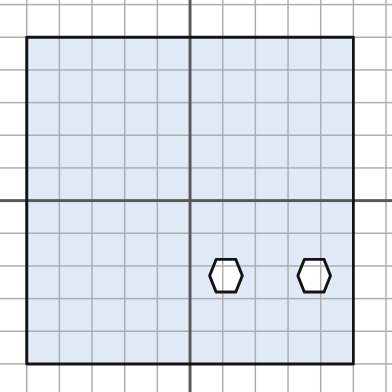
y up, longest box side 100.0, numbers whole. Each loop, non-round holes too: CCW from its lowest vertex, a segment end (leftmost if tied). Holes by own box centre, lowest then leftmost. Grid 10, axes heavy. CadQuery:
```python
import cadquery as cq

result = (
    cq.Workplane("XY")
    .moveTo(-50.0, -50.0)
    .lineTo(50.0, -50.0)
    .lineTo(50.0, 50.0)
    .lineTo(-50.0, 50.0)
    .close()
    .moveTo(8.0, -28.0)
    .lineTo(14.0, -28.0)
    .lineTo(16.0, -23.0)
    .lineTo(14.0, -18.0)
    .lineTo(8.0, -18.0)
    .lineTo(6.0, -23.0)
    .close()
    .moveTo(35.0, -28.0)
    .lineTo(41.0, -28.0)
    .lineTo(43.0, -23.0)
    .lineTo(41.0, -18.0)
    .lineTo(35.0, -18.0)
    .lineTo(33.0, -23.0)
    .close()
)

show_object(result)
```